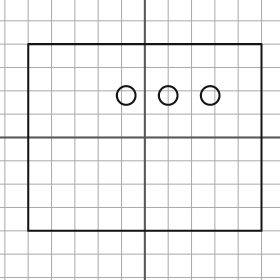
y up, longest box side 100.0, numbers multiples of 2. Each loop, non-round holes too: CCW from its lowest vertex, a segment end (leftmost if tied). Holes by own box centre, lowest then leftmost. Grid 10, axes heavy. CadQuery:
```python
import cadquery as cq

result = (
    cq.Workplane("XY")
    .moveTo(-50.0, -40.0)
    .lineTo(50.0, -40.0)
    .lineTo(50.0, 40.0)
    .lineTo(-50.0, 40.0)
    .close()
    .moveTo(-8.0, 18.0)
    .circle(4.0)
    .moveTo(10.0, 18.0)
    .circle(4.0)
    .moveTo(28.0, 18.0)
    .circle(4.0)
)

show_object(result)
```